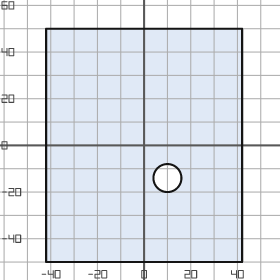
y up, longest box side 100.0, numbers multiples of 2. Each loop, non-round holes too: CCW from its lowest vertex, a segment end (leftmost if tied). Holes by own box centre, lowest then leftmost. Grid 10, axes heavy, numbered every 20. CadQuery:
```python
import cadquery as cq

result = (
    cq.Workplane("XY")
    .moveTo(-42.0, -50.0)
    .lineTo(42.0, -50.0)
    .lineTo(42.0, 50.0)
    .lineTo(-42.0, 50.0)
    .close()
    .moveTo(10.0, -14.0)
    .circle(6.0)
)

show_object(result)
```